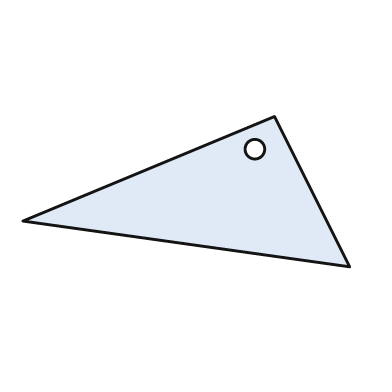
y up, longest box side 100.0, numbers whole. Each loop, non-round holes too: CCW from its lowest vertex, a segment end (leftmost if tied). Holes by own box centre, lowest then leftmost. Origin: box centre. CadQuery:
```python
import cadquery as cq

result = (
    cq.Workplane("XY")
    .moveTo(50.0, -23.0)
    .lineTo(27.0, 23.0)
    .lineTo(-50.0, -9.0)
    .close()
    .moveTo(21.0, 13.0)
    .circle(3.0)
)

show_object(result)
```